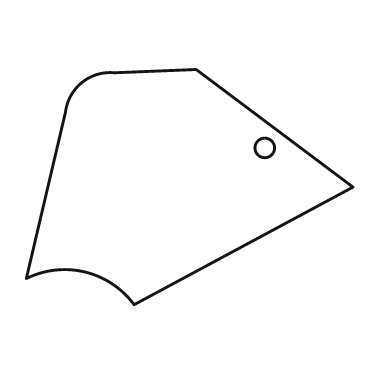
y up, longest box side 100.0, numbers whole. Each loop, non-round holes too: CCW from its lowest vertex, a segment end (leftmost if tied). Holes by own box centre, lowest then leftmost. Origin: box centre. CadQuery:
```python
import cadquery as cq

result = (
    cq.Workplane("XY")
    .moveTo(-17.0, -36.0)
    .lineTo(50.0, 0.0)
    .lineTo(2.0, 36.0)
    .lineTo(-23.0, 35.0)
    .threePointArc((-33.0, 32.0), (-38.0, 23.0))
    .lineTo(-50.0, -28.0)
    .threePointArc((-32.0, -26.0), (-17.0, -36.0))
    .close()
    .moveTo(23.0, 12.0)
    .circle(3.0)
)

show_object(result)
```